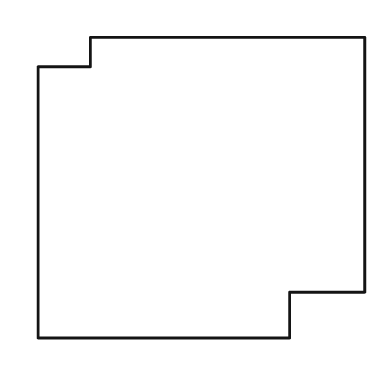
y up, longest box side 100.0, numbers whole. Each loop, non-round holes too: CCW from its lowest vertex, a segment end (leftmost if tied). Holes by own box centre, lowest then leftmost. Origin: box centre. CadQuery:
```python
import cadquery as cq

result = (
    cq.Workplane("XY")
    .moveTo(-50.0, -46.0)
    .lineTo(27.0, -46.0)
    .lineTo(27.0, -32.0)
    .lineTo(50.0, -32.0)
    .lineTo(50.0, 46.0)
    .lineTo(-34.0, 46.0)
    .lineTo(-34.0, 37.0)
    .lineTo(-50.0, 37.0)
    .close()
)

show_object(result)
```